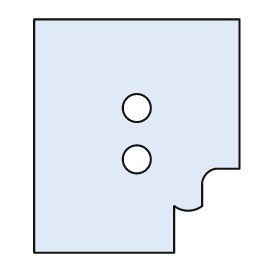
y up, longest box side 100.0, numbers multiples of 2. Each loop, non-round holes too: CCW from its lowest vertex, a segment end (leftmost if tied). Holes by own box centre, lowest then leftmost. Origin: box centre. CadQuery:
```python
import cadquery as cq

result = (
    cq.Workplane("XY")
    .moveTo(-44.0, -50.0)
    .lineTo(16.0, -50.0)
    .lineTo(16.0, -30.0)
    .threePointArc((22.0, -32.0), (28.0, -30.0))
    .lineTo(28.0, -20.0)
    .threePointArc((30.0, -16.0), (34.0, -14.0))
    .lineTo(44.0, -14.0)
    .lineTo(44.0, 50.0)
    .lineTo(-44.0, 50.0)
    .close()
    .moveTo(0.0, -10.0)
    .circle(6.0)
    .moveTo(0.0, 12.0)
    .circle(6.0)
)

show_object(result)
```